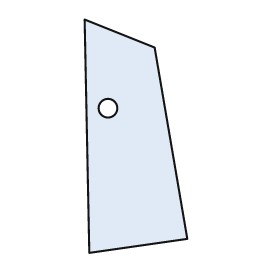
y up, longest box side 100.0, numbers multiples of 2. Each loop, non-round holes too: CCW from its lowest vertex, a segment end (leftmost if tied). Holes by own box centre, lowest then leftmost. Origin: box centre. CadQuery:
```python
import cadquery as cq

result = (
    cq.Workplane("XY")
    .moveTo(-20.0, -50.0)
    .lineTo(22.0, -44.0)
    .lineTo(8.0, 38.0)
    .lineTo(-22.0, 50.0)
    .close()
    .moveTo(-12.0, 12.0)
    .circle(4.0)
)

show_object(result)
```